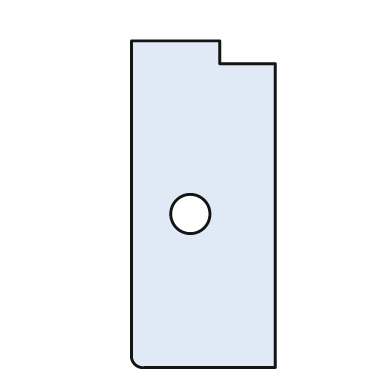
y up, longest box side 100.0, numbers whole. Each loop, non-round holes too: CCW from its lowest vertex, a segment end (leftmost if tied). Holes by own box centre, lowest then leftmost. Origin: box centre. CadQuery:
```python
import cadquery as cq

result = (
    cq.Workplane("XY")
    .moveTo(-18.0, -50.0)
    .lineTo(22.0, -50.0)
    .lineTo(22.0, 43.0)
    .lineTo(5.0, 43.0)
    .lineTo(5.0, 50.0)
    .lineTo(-22.0, 50.0)
    .lineTo(-22.0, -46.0)
    .threePointArc((-21.0, -49.0), (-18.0, -50.0))
    .close()
    .moveTo(-4.0, -3.0)
    .circle(6.0)
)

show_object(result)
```